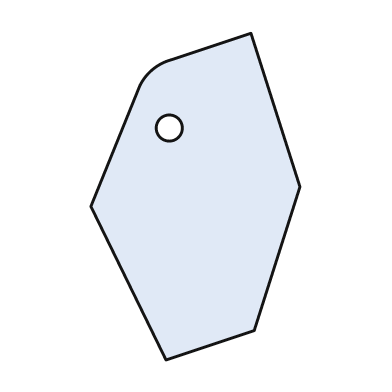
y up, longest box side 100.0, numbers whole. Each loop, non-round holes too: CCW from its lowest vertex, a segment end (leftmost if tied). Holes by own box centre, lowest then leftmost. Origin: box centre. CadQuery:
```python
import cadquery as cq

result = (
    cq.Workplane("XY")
    .moveTo(-9.0, -50.0)
    .lineTo(18.0, -41.0)
    .lineTo(32.0, 3.0)
    .lineTo(17.0, 50.0)
    .lineTo(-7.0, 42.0)
    .threePointArc((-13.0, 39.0), (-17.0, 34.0))
    .lineTo(-32.0, -3.0)
    .close()
    .moveTo(-8.0, 21.0)
    .circle(4.0)
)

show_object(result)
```